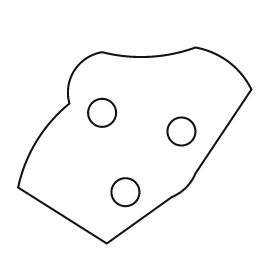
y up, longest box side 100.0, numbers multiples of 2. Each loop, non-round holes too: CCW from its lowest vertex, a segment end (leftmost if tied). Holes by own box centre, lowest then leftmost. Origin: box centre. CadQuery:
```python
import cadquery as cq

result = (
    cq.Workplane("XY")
    .moveTo(-12.0, -42.0)
    .lineTo(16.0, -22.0)
    .threePointArc((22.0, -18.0), (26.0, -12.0))
    .lineTo(50.0, 24.0)
    .threePointArc((40.0, 36.0), (26.0, 42.0))
    .threePointArc((6.0, 38.0), (-14.0, 40.0))
    .threePointArc((-26.0, 32.0), (-28.0, 18.0))
    .threePointArc((-42.0, 2.0), (-50.0, -18.0))
    .close()
    .moveTo(-4.0, -20.0)
    .circle(6.0)
    .moveTo(20.0, 6.0)
    .circle(6.0)
    .moveTo(-14.0, 14.0)
    .circle(6.0)
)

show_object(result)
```